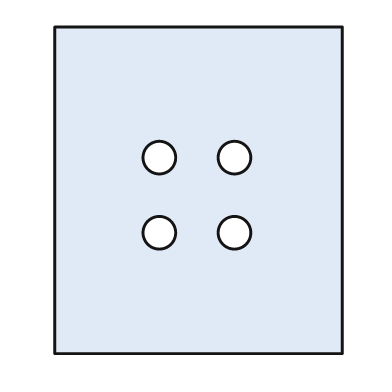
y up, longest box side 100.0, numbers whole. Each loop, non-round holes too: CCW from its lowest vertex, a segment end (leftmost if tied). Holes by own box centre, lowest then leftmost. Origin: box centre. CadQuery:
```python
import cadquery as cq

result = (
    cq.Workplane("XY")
    .moveTo(-44.0, -50.0)
    .lineTo(44.0, -50.0)
    .lineTo(44.0, 50.0)
    .lineTo(-44.0, 50.0)
    .close()
    .moveTo(-12.0, -13.0)
    .circle(5.0)
    .moveTo(11.0, -13.0)
    .circle(5.0)
    .moveTo(-12.0, 10.0)
    .circle(5.0)
    .moveTo(11.0, 10.0)
    .circle(5.0)
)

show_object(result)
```